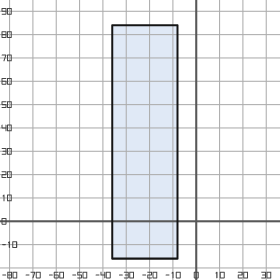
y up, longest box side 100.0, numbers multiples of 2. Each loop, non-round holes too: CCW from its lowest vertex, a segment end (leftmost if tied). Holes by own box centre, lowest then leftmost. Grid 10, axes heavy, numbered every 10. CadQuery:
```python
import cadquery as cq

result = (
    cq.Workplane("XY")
    .moveTo(-36.0, -16.0)
    .lineTo(-8.0, -16.0)
    .lineTo(-8.0, 84.0)
    .lineTo(-36.0, 84.0)
    .close()
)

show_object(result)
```